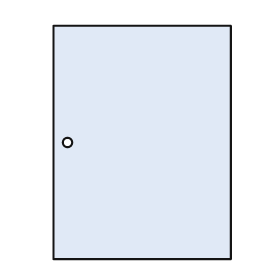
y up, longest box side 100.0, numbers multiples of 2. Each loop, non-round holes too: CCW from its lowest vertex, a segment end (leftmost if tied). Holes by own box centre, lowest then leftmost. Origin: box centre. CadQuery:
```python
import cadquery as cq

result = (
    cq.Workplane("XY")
    .moveTo(-38.0, -50.0)
    .lineTo(38.0, -50.0)
    .lineTo(38.0, 50.0)
    .lineTo(-38.0, 50.0)
    .close()
    .moveTo(-32.0, 0.0)
    .circle(2.0)
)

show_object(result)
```